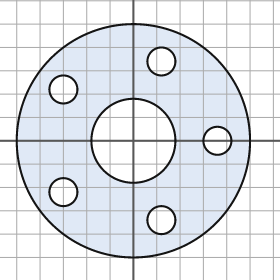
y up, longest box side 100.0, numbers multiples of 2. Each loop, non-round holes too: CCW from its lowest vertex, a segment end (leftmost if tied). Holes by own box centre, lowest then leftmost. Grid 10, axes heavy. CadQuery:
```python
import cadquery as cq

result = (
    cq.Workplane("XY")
    .moveTo(0.0, 0.0)
    .circle(50.0)
    .moveTo(12.0, -34.0)
    .circle(6.0)
    .moveTo(-30.0, -22.0)
    .circle(6.0)
    .moveTo(0.0, 0.0)
    .circle(18.0)
    .moveTo(36.0, 0.0)
    .circle(6.0)
    .moveTo(-30.0, 22.0)
    .circle(6.0)
    .moveTo(12.0, 34.0)
    .circle(6.0)
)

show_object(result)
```